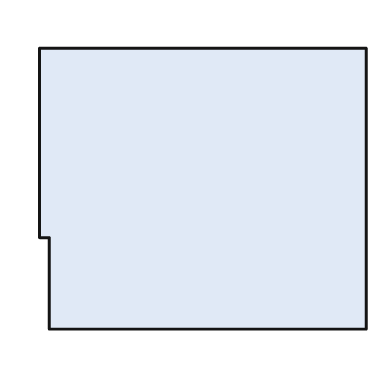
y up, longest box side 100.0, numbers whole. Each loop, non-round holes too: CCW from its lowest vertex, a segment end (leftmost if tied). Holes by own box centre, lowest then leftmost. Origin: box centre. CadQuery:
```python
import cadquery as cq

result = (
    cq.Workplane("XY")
    .moveTo(-47.0, -43.0)
    .lineTo(50.0, -43.0)
    .lineTo(50.0, 43.0)
    .lineTo(-50.0, 43.0)
    .lineTo(-50.0, -15.0)
    .lineTo(-47.0, -15.0)
    .close()
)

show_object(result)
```